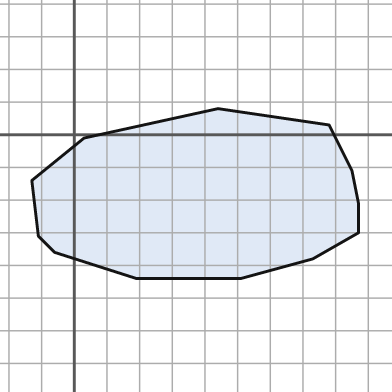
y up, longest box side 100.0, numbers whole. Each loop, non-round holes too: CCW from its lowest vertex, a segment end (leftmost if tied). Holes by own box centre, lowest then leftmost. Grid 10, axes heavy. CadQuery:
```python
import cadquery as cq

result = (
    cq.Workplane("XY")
    .moveTo(19.0, -44.0)
    .lineTo(51.0, -44.0)
    .lineTo(73.0, -38.0)
    .lineTo(87.0, -30.0)
    .lineTo(87.0, -21.0)
    .lineTo(85.0, -11.0)
    .lineTo(78.0, 3.0)
    .lineTo(44.0, 8.0)
    .lineTo(3.0, -1.0)
    .lineTo(-13.0, -14.0)
    .lineTo(-11.0, -31.0)
    .lineTo(-6.0, -36.0)
    .close()
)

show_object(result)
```